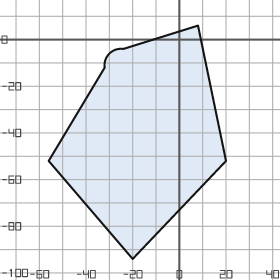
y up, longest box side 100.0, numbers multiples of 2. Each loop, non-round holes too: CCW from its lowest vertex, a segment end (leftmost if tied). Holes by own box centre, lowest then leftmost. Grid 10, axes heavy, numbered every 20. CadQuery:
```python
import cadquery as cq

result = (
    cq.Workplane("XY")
    .moveTo(-20.0, -94.0)
    .lineTo(20.0, -52.0)
    .lineTo(8.0, 6.0)
    .lineTo(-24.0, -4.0)
    .threePointArc((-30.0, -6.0), (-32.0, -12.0))
    .lineTo(-56.0, -52.0)
    .close()
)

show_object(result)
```